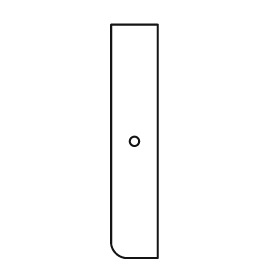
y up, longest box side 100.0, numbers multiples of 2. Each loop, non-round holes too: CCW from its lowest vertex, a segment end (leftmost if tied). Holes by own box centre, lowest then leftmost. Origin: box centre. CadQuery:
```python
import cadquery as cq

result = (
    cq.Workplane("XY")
    .moveTo(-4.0, -50.0)
    .lineTo(10.0, -50.0)
    .lineTo(10.0, 50.0)
    .lineTo(-10.0, 50.0)
    .lineTo(-10.0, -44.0)
    .threePointArc((-8.0, -48.0), (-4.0, -50.0))
    .close()
    .moveTo(0.0, 0.0)
    .circle(2.0)
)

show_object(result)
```